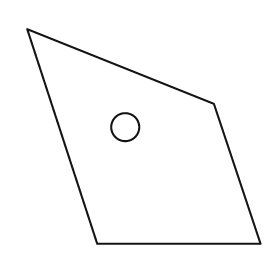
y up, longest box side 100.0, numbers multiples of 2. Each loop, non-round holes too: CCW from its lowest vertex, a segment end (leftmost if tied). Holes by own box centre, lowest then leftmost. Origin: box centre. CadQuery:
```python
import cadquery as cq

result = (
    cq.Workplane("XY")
    .moveTo(-20.0, -46.0)
    .lineTo(50.0, -46.0)
    .lineTo(30.0, 14.0)
    .lineTo(-50.0, 46.0)
    .close()
    .moveTo(-8.0, 4.0)
    .circle(6.0)
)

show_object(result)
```